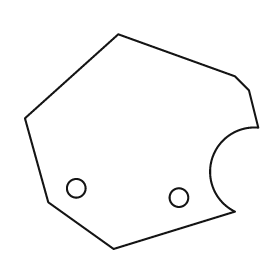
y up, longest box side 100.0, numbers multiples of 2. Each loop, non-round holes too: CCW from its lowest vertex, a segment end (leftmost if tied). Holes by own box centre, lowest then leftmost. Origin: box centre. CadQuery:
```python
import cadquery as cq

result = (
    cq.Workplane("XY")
    .moveTo(-12.0, -46.0)
    .lineTo(40.0, -30.0)
    .threePointArc((30.0, -8.0), (50.0, 6.0))
    .lineTo(46.0, 22.0)
    .lineTo(40.0, 28.0)
    .lineTo(-10.0, 46.0)
    .lineTo(-50.0, 10.0)
    .lineTo(-40.0, -26.0)
    .close()
    .moveTo(16.0, -24.0)
    .circle(4.0)
    .moveTo(-28.0, -20.0)
    .circle(4.0)
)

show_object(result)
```